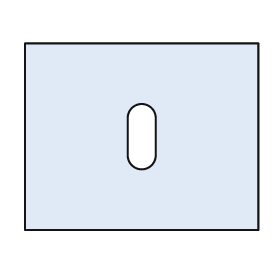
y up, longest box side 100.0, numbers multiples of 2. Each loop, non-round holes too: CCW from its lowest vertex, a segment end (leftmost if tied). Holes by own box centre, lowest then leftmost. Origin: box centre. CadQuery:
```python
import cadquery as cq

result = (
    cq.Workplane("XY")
    .moveTo(-50.0, -40.0)
    .lineTo(50.0, -40.0)
    .lineTo(50.0, 40.0)
    .lineTo(-50.0, 40.0)
    .close()
    .moveTo(-6.0, -8.0)
    .threePointArc((0.0, -14.0), (6.0, -8.0))
    .lineTo(6.0, 8.0)
    .threePointArc((0.0, 14.0), (-6.0, 8.0))
    .close()
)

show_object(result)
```